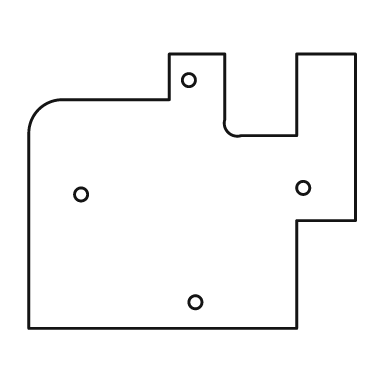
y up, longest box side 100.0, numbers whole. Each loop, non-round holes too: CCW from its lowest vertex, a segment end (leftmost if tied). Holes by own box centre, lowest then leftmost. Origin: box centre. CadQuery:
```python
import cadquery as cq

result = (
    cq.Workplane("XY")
    .moveTo(-50.0, -42.0)
    .lineTo(32.0, -42.0)
    .lineTo(32.0, -9.0)
    .lineTo(50.0, -9.0)
    .lineTo(50.0, 42.0)
    .lineTo(32.0, 42.0)
    .lineTo(32.0, 17.0)
    .lineTo(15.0, 17.0)
    .threePointArc((11.0, 18.0), (10.0, 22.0))
    .lineTo(10.0, 42.0)
    .lineTo(-7.0, 42.0)
    .lineTo(-7.0, 28.0)
    .lineTo(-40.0, 28.0)
    .threePointArc((-47.0, 25.0), (-50.0, 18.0))
    .close()
    .moveTo(1.0, -34.0)
    .circle(2.0)
    .moveTo(-34.0, -1.0)
    .circle(2.0)
    .moveTo(34.0, 1.0)
    .circle(2.0)
    .moveTo(-1.0, 34.0)
    .circle(2.0)
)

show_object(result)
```